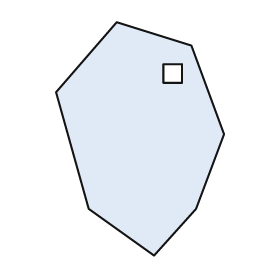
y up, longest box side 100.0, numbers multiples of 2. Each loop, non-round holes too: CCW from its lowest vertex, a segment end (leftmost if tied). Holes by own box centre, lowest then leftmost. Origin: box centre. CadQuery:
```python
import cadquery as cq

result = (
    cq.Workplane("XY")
    .moveTo(6.0, -50.0)
    .lineTo(24.0, -30.0)
    .lineTo(36.0, 2.0)
    .lineTo(22.0, 40.0)
    .lineTo(-10.0, 50.0)
    .lineTo(-36.0, 20.0)
    .lineTo(-22.0, -30.0)
    .close()
    .moveTo(10.0, 24.0)
    .lineTo(18.0, 24.0)
    .lineTo(18.0, 32.0)
    .lineTo(10.0, 32.0)
    .close()
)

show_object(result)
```